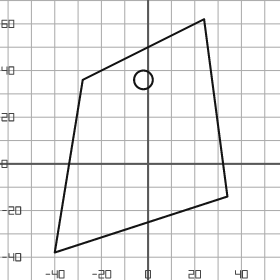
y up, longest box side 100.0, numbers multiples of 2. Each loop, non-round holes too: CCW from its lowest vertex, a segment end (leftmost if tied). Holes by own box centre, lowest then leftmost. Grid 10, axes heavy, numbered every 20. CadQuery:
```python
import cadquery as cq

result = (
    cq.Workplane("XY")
    .moveTo(-40.0, -38.0)
    .lineTo(34.0, -14.0)
    .lineTo(24.0, 62.0)
    .lineTo(-28.0, 36.0)
    .close()
    .moveTo(-2.0, 36.0)
    .circle(4.0)
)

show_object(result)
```